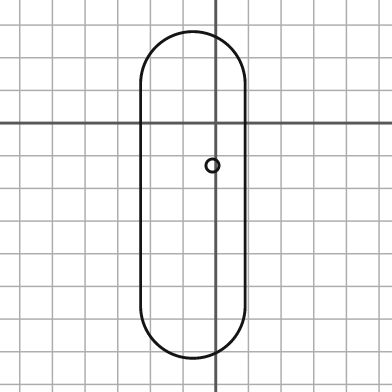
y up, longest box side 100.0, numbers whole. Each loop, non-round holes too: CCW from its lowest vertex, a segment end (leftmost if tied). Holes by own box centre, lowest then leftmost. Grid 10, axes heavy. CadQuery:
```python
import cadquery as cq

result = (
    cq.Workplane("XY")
    .moveTo(-23.0, -56.0)
    .threePointArc((-7.0, -72.0), (9.0, -56.0))
    .lineTo(9.0, 12.0)
    .threePointArc((-7.0, 28.0), (-23.0, 12.0))
    .close()
    .moveTo(-1.0, -13.0)
    .circle(2.0)
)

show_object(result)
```